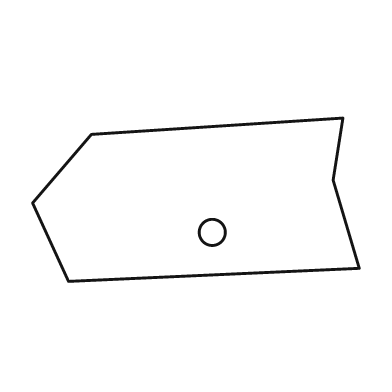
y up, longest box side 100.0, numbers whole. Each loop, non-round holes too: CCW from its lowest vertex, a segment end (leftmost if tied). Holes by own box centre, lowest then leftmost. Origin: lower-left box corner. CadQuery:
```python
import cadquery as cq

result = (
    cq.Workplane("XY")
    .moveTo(11.0, 0.0)
    .lineTo(100.0, 4.0)
    .lineTo(92.0, 31.0)
    .lineTo(95.0, 50.0)
    .lineTo(18.0, 45.0)
    .lineTo(0.0, 24.0)
    .close()
    .moveTo(55.0, 15.0)
    .circle(4.0)
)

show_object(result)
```